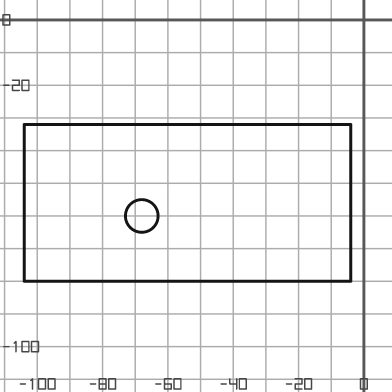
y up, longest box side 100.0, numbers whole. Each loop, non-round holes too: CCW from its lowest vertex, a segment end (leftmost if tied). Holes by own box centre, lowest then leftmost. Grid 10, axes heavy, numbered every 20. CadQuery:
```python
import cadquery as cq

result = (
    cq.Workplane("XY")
    .moveTo(-104.0, -80.0)
    .lineTo(-4.0, -80.0)
    .lineTo(-4.0, -32.0)
    .lineTo(-104.0, -32.0)
    .close()
    .moveTo(-68.0, -60.0)
    .circle(5.0)
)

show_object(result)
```